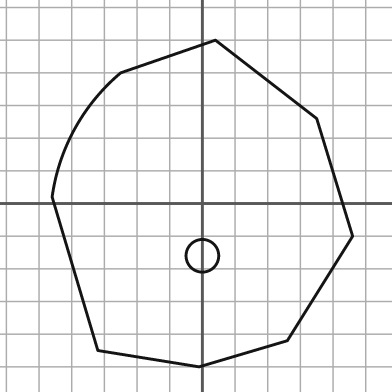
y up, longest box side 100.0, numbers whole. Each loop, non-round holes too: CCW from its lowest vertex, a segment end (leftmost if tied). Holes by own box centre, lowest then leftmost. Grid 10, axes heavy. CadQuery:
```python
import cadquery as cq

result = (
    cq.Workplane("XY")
    .moveTo(-1.0, -50.0)
    .lineTo(26.0, -42.0)
    .lineTo(46.0, -10.0)
    .lineTo(35.0, 26.0)
    .lineTo(4.0, 50.0)
    .lineTo(-25.0, 40.0)
    .threePointArc((-39.0, 23.0), (-46.0, 2.0))
    .lineTo(-32.0, -45.0)
    .close()
    .moveTo(0.0, -16.0)
    .circle(5.0)
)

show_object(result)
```